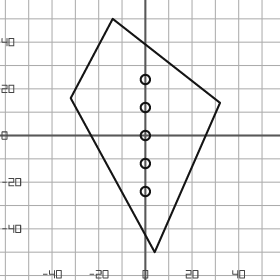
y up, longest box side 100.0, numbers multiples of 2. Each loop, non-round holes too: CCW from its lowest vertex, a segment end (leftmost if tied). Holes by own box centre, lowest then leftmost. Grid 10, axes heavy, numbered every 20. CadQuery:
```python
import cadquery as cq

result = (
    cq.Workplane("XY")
    .moveTo(4.0, -50.0)
    .lineTo(32.0, 14.0)
    .lineTo(-14.0, 50.0)
    .lineTo(-32.0, 16.0)
    .close()
    .moveTo(0.0, -24.0)
    .circle(2.0)
    .moveTo(0.0, -12.0)
    .circle(2.0)
    .moveTo(0.0, 0.0)
    .circle(2.0)
    .moveTo(0.0, 12.0)
    .circle(2.0)
    .moveTo(0.0, 24.0)
    .circle(2.0)
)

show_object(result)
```